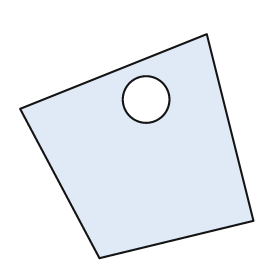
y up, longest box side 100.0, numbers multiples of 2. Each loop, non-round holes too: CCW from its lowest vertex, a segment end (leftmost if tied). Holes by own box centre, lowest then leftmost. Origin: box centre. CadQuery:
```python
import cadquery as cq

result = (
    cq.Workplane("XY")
    .moveTo(-16.0, -48.0)
    .lineTo(50.0, -32.0)
    .lineTo(30.0, 48.0)
    .lineTo(-50.0, 16.0)
    .close()
    .moveTo(4.0, 20.0)
    .circle(10.0)
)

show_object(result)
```